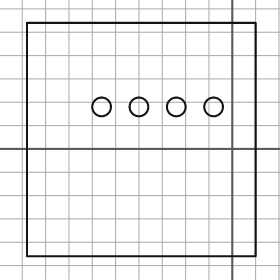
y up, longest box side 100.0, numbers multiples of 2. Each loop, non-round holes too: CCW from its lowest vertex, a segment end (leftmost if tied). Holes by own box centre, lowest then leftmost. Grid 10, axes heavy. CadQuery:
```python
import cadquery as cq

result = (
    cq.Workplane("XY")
    .moveTo(-88.0, -46.0)
    .lineTo(10.0, -46.0)
    .lineTo(10.0, 54.0)
    .lineTo(-88.0, 54.0)
    .close()
    .moveTo(-56.0, 18.0)
    .circle(4.0)
    .moveTo(-40.0, 18.0)
    .circle(4.0)
    .moveTo(-24.0, 18.0)
    .circle(4.0)
    .moveTo(-8.0, 18.0)
    .circle(4.0)
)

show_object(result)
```